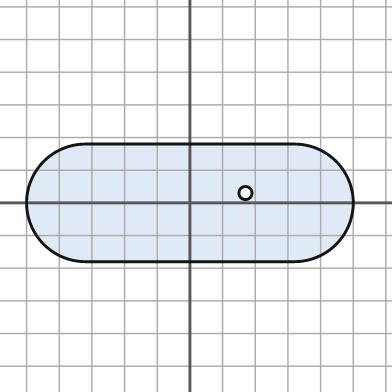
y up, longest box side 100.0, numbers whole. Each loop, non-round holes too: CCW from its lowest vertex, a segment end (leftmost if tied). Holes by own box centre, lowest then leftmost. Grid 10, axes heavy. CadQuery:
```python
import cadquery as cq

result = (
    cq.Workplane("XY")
    .moveTo(-32.0, -18.0)
    .lineTo(32.0, -18.0)
    .threePointArc((50.0, 0.0), (32.0, 18.0))
    .lineTo(-32.0, 18.0)
    .threePointArc((-50.0, 0.0), (-32.0, -18.0))
    .close()
    .moveTo(17.0, 3.0)
    .circle(2.0)
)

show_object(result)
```